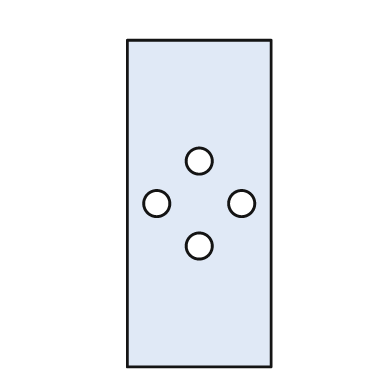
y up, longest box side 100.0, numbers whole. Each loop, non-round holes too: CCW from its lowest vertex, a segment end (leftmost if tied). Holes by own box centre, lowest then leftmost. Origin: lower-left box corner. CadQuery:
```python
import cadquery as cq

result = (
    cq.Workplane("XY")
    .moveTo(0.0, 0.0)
    .lineTo(44.0, 0.0)
    .lineTo(44.0, 100.0)
    .lineTo(0.0, 100.0)
    .close()
    .moveTo(22.0, 37.0)
    .circle(4.0)
    .moveTo(9.0, 50.0)
    .circle(4.0)
    .moveTo(35.0, 50.0)
    .circle(4.0)
    .moveTo(22.0, 63.0)
    .circle(4.0)
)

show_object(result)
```